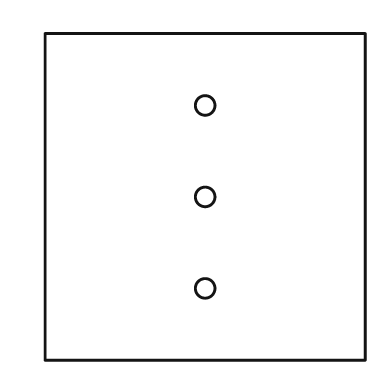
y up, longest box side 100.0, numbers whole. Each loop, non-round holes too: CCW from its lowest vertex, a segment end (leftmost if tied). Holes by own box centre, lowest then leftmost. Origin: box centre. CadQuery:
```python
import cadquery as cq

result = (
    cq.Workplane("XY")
    .moveTo(-49.0, -50.0)
    .lineTo(49.0, -50.0)
    .lineTo(49.0, 50.0)
    .lineTo(-49.0, 50.0)
    .close()
    .moveTo(0.0, -28.0)
    .circle(3.0)
    .moveTo(0.0, 0.0)
    .circle(3.0)
    .moveTo(0.0, 28.0)
    .circle(3.0)
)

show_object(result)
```